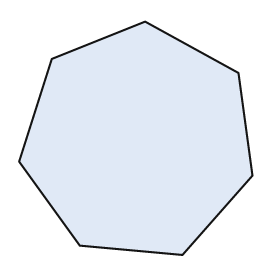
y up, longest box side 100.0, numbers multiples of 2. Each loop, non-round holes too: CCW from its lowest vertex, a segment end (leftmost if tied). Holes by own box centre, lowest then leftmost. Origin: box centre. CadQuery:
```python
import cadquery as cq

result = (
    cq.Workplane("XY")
    .moveTo(20.0, -50.0)
    .lineTo(50.0, -16.0)
    .lineTo(44.0, 28.0)
    .lineTo(4.0, 50.0)
    .lineTo(-36.0, 34.0)
    .lineTo(-50.0, -10.0)
    .lineTo(-24.0, -46.0)
    .close()
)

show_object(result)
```